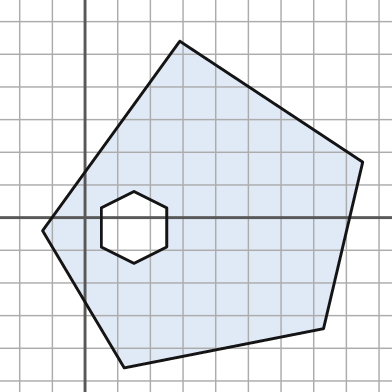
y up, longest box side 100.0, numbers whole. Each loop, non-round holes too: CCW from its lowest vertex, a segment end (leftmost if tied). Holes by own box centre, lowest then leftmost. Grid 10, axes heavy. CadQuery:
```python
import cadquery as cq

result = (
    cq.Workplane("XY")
    .moveTo(12.0, -46.0)
    .lineTo(73.0, -34.0)
    .lineTo(85.0, 17.0)
    .lineTo(29.0, 54.0)
    .lineTo(-13.0, -4.0)
    .close()
    .moveTo(15.0, -14.0)
    .lineTo(25.0, -9.0)
    .lineTo(25.0, 3.0)
    .lineTo(15.0, 8.0)
    .lineTo(5.0, 3.0)
    .lineTo(5.0, -9.0)
    .close()
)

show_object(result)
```